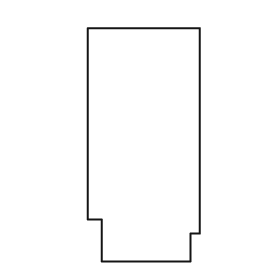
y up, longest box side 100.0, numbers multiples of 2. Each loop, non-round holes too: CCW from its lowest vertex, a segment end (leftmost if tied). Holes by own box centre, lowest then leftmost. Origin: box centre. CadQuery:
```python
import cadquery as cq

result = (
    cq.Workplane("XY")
    .moveTo(-18.0, -50.0)
    .lineTo(20.0, -50.0)
    .lineTo(20.0, -38.0)
    .lineTo(24.0, -38.0)
    .lineTo(24.0, 50.0)
    .lineTo(-24.0, 50.0)
    .lineTo(-24.0, -32.0)
    .lineTo(-18.0, -32.0)
    .close()
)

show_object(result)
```